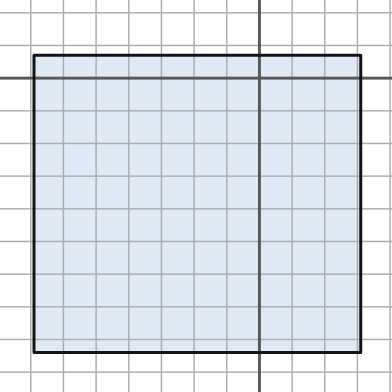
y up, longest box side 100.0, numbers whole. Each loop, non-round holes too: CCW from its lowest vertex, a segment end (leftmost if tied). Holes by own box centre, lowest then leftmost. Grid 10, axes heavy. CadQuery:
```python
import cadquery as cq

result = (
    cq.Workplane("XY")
    .moveTo(-69.0, -84.0)
    .lineTo(31.0, -84.0)
    .lineTo(31.0, 7.0)
    .lineTo(-69.0, 7.0)
    .close()
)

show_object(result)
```